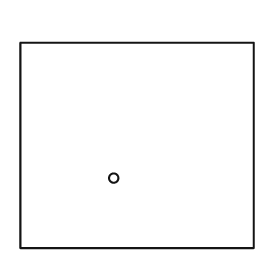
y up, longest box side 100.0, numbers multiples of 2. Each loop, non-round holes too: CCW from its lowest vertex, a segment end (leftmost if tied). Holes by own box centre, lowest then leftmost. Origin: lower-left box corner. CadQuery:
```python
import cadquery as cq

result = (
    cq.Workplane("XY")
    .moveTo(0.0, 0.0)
    .lineTo(100.0, 0.0)
    .lineTo(100.0, 88.0)
    .lineTo(0.0, 88.0)
    .close()
    .moveTo(40.0, 30.0)
    .circle(2.0)
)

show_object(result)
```